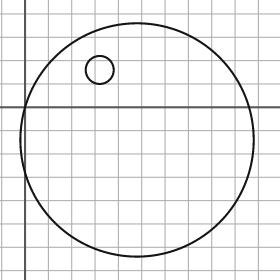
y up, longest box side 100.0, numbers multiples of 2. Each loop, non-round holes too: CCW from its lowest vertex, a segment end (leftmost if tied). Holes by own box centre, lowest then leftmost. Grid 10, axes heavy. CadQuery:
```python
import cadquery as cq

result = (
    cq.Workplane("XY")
    .moveTo(48.0, -14.0)
    .circle(50.0)
    .moveTo(32.0, 16.0)
    .circle(6.0)
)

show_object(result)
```